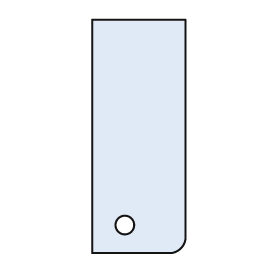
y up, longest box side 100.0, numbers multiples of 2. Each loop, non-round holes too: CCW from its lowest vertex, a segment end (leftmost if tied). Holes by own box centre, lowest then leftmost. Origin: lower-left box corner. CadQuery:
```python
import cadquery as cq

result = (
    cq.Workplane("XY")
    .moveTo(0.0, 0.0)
    .lineTo(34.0, 0.0)
    .threePointArc((38.0, 2.0), (40.0, 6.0))
    .lineTo(40.0, 100.0)
    .lineTo(0.0, 100.0)
    .close()
    .moveTo(14.0, 12.0)
    .circle(4.0)
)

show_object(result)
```